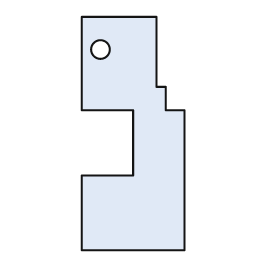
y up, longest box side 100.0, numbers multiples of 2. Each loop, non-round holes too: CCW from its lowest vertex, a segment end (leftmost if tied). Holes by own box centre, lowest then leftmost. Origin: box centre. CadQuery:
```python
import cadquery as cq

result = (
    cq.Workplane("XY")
    .moveTo(-22.0, -50.0)
    .lineTo(22.0, -50.0)
    .lineTo(22.0, 10.0)
    .lineTo(14.0, 10.0)
    .lineTo(14.0, 20.0)
    .lineTo(10.0, 20.0)
    .lineTo(10.0, 50.0)
    .lineTo(-22.0, 50.0)
    .lineTo(-22.0, 10.0)
    .lineTo(0.0, 10.0)
    .lineTo(0.0, -18.0)
    .lineTo(-22.0, -18.0)
    .close()
    .moveTo(-14.0, 36.0)
    .circle(4.0)
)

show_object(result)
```